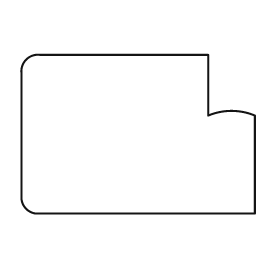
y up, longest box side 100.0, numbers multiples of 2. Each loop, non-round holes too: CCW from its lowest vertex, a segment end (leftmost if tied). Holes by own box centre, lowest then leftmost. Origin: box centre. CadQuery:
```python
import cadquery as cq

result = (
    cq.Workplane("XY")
    .moveTo(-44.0, -34.0)
    .lineTo(50.0, -34.0)
    .lineTo(50.0, 8.0)
    .threePointArc((40.0, 10.0), (30.0, 8.0))
    .lineTo(30.0, 34.0)
    .lineTo(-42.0, 34.0)
    .threePointArc((-48.0, 32.0), (-50.0, 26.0))
    .lineTo(-50.0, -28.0)
    .threePointArc((-48.0, -32.0), (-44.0, -34.0))
    .close()
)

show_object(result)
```